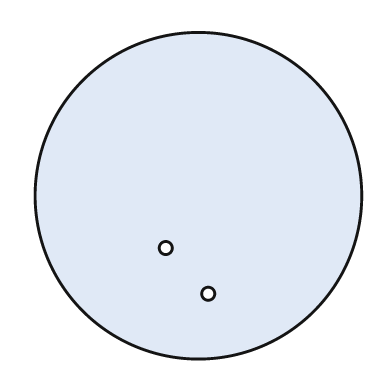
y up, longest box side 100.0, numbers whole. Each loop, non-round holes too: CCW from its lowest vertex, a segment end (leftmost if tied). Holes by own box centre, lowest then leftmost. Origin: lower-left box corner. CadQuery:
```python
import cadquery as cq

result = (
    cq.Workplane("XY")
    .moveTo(50.0, 50.0)
    .circle(50.0)
    .moveTo(53.0, 20.0)
    .circle(2.0)
    .moveTo(40.0, 34.0)
    .circle(2.0)
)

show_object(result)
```